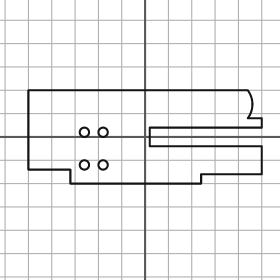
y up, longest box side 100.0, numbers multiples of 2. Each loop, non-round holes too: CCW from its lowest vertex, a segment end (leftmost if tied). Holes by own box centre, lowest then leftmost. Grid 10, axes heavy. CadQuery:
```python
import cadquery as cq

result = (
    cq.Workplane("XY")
    .moveTo(-32.0, -20.0)
    .lineTo(24.0, -20.0)
    .lineTo(24.0, -16.0)
    .lineTo(50.0, -16.0)
    .lineTo(50.0, -4.0)
    .lineTo(2.0, -4.0)
    .lineTo(2.0, 4.0)
    .lineTo(50.0, 4.0)
    .lineTo(50.0, 8.0)
    .lineTo(44.0, 8.0)
    .threePointArc((46.0, 14.0), (44.0, 20.0))
    .lineTo(-50.0, 20.0)
    .lineTo(-50.0, -14.0)
    .lineTo(-32.0, -14.0)
    .close()
    .moveTo(-26.0, -12.0)
    .circle(2.0)
    .moveTo(-18.0, -12.0)
    .circle(2.0)
    .moveTo(-26.0, 2.0)
    .circle(2.0)
    .moveTo(-18.0, 2.0)
    .circle(2.0)
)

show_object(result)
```